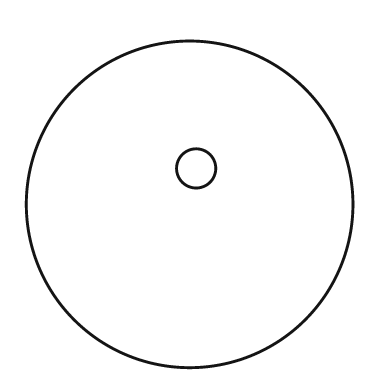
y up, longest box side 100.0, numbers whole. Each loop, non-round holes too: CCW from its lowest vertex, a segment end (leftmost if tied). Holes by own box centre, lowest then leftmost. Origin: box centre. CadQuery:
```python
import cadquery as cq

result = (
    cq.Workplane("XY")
    .moveTo(0.0, 0.0)
    .circle(50.0)
    .moveTo(2.0, 11.0)
    .circle(6.0)
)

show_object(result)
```